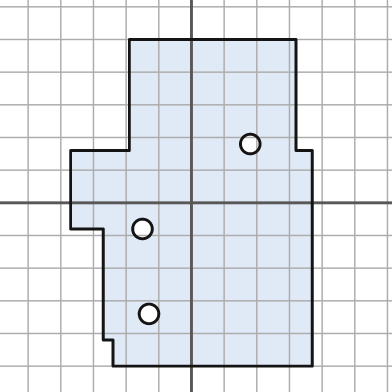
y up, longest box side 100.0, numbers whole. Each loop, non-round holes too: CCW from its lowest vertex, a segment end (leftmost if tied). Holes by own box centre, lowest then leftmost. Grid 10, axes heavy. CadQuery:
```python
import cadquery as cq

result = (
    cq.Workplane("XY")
    .moveTo(-24.0, -50.0)
    .lineTo(37.0, -50.0)
    .lineTo(37.0, 16.0)
    .lineTo(32.0, 16.0)
    .lineTo(32.0, 50.0)
    .lineTo(-19.0, 50.0)
    .lineTo(-19.0, 16.0)
    .lineTo(-37.0, 16.0)
    .lineTo(-37.0, -8.0)
    .lineTo(-27.0, -8.0)
    .lineTo(-27.0, -42.0)
    .lineTo(-24.0, -42.0)
    .close()
    .moveTo(-13.0, -34.0)
    .circle(3.0)
    .moveTo(-15.0, -8.0)
    .circle(3.0)
    .moveTo(18.0, 18.0)
    .circle(3.0)
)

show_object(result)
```